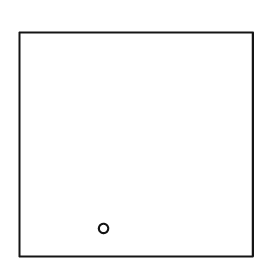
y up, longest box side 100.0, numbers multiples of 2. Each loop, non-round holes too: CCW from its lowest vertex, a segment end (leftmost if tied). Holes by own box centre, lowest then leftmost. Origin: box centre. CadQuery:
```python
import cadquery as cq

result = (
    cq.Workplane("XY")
    .moveTo(-50.0, -48.0)
    .lineTo(50.0, -48.0)
    .lineTo(50.0, 48.0)
    .lineTo(-50.0, 48.0)
    .close()
    .moveTo(-14.0, -36.0)
    .circle(2.0)
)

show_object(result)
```